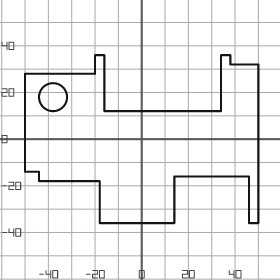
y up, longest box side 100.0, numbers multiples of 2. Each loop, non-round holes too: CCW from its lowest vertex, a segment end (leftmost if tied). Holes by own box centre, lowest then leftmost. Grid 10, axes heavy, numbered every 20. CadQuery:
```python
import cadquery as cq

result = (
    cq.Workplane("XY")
    .moveTo(-18.0, -36.0)
    .lineTo(14.0, -36.0)
    .lineTo(14.0, -16.0)
    .lineTo(46.0, -16.0)
    .lineTo(46.0, -36.0)
    .lineTo(50.0, -36.0)
    .lineTo(50.0, 32.0)
    .lineTo(38.0, 32.0)
    .lineTo(38.0, 36.0)
    .lineTo(34.0, 36.0)
    .lineTo(34.0, 12.0)
    .lineTo(-16.0, 12.0)
    .lineTo(-16.0, 36.0)
    .lineTo(-20.0, 36.0)
    .lineTo(-20.0, 28.0)
    .lineTo(-50.0, 28.0)
    .lineTo(-50.0, -14.0)
    .lineTo(-44.0, -14.0)
    .lineTo(-44.0, -18.0)
    .lineTo(-18.0, -18.0)
    .close()
    .moveTo(-38.0, 18.0)
    .circle(6.0)
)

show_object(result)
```